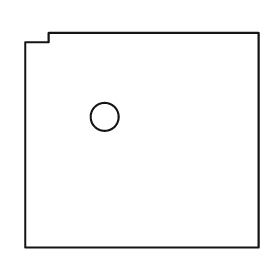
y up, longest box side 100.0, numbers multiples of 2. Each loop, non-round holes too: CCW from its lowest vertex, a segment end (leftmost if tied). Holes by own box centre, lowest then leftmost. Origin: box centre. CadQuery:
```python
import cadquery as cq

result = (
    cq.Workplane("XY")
    .moveTo(-50.0, -46.0)
    .lineTo(50.0, -46.0)
    .lineTo(50.0, 46.0)
    .lineTo(-40.0, 46.0)
    .lineTo(-40.0, 42.0)
    .lineTo(-50.0, 42.0)
    .close()
    .moveTo(-16.0, 10.0)
    .circle(6.0)
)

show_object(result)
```